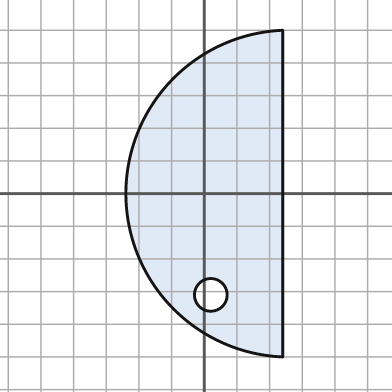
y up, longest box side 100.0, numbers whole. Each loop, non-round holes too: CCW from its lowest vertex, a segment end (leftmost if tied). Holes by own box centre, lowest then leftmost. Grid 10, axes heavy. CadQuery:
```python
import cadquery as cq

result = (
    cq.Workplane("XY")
    .moveTo(24.0, -50.0)
    .lineTo(24.0, 50.0)
    .threePointArc((-24.0, 0.0), (24.0, -50.0))
    .close()
    .moveTo(2.0, -31.0)
    .circle(5.0)
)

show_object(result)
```